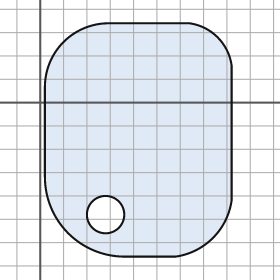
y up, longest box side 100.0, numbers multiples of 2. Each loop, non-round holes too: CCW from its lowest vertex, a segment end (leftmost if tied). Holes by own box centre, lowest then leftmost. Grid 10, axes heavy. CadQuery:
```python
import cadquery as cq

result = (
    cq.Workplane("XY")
    .moveTo(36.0, -66.0)
    .lineTo(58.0, -66.0)
    .threePointArc((74.0, -58.0), (82.0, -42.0))
    .lineTo(82.0, 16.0)
    .threePointArc((76.0, 28.0), (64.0, 34.0))
    .lineTo(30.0, 34.0)
    .threePointArc((10.0, 26.0), (2.0, 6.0))
    .lineTo(2.0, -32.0)
    .threePointArc((12.0, -56.0), (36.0, -66.0))
    .close()
    .moveTo(28.0, -48.0)
    .circle(8.0)
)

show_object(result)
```